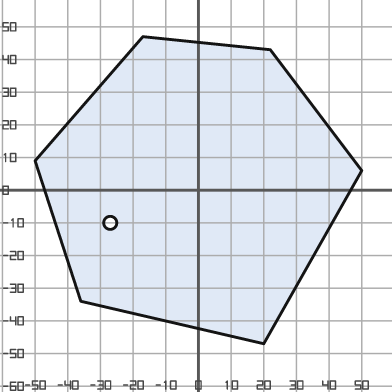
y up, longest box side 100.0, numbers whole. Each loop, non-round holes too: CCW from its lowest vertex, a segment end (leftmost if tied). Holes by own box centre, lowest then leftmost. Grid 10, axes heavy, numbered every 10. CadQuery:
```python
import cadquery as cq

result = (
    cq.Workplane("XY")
    .moveTo(20.0, -47.0)
    .lineTo(50.0, 6.0)
    .lineTo(22.0, 43.0)
    .lineTo(-17.0, 47.0)
    .lineTo(-50.0, 9.0)
    .lineTo(-36.0, -34.0)
    .close()
    .moveTo(-27.0, -10.0)
    .circle(2.0)
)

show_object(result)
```